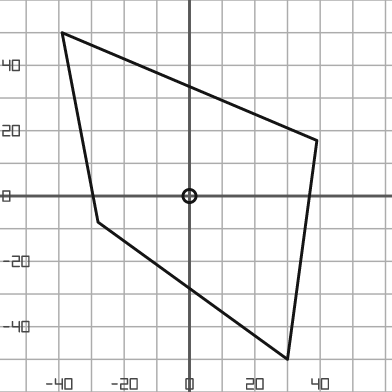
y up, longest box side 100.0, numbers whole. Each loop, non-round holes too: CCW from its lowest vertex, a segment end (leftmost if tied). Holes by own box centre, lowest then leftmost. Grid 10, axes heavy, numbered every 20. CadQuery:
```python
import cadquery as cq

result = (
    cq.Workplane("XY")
    .moveTo(30.0, -50.0)
    .lineTo(39.0, 17.0)
    .lineTo(-39.0, 50.0)
    .lineTo(-28.0, -8.0)
    .close()
    .moveTo(0.0, 0.0)
    .circle(2.0)
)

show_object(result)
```